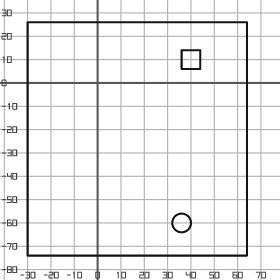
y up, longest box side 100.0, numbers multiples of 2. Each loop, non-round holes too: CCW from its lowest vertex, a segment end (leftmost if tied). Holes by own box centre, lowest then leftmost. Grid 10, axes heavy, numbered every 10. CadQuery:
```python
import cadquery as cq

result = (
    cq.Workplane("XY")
    .moveTo(-30.0, -74.0)
    .lineTo(64.0, -74.0)
    .lineTo(64.0, 26.0)
    .lineTo(-30.0, 26.0)
    .close()
    .moveTo(36.0, -60.0)
    .circle(4.0)
    .moveTo(36.0, 6.0)
    .lineTo(44.0, 6.0)
    .lineTo(44.0, 14.0)
    .lineTo(36.0, 14.0)
    .close()
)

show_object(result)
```